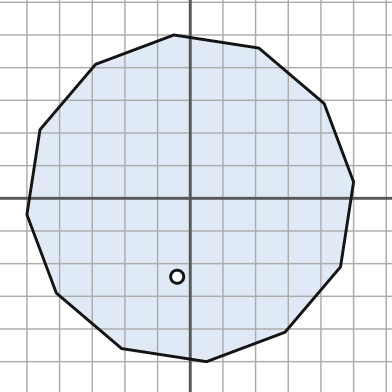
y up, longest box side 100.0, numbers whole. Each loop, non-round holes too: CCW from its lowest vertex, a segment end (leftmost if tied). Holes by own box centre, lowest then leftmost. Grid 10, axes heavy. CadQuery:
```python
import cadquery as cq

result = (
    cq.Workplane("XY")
    .moveTo(5.0, -50.0)
    .lineTo(29.0, -41.0)
    .lineTo(46.0, -21.0)
    .lineTo(50.0, 5.0)
    .lineTo(41.0, 29.0)
    .lineTo(21.0, 46.0)
    .lineTo(-5.0, 50.0)
    .lineTo(-29.0, 41.0)
    .lineTo(-46.0, 21.0)
    .lineTo(-50.0, -5.0)
    .lineTo(-41.0, -29.0)
    .lineTo(-21.0, -46.0)
    .close()
    .moveTo(-4.0, -24.0)
    .circle(2.0)
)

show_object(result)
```